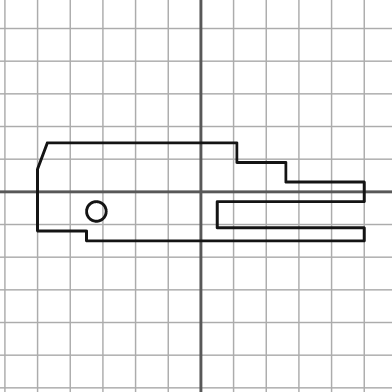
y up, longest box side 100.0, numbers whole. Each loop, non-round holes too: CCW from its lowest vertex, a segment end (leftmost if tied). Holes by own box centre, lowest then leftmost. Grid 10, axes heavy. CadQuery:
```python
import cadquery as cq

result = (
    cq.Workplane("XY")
    .moveTo(-35.0, -15.0)
    .lineTo(50.0, -15.0)
    .lineTo(50.0, -11.0)
    .lineTo(5.0, -11.0)
    .lineTo(5.0, -3.0)
    .lineTo(50.0, -3.0)
    .lineTo(50.0, 3.0)
    .lineTo(26.0, 3.0)
    .lineTo(26.0, 9.0)
    .lineTo(11.0, 9.0)
    .lineTo(11.0, 15.0)
    .lineTo(-47.0, 15.0)
    .lineTo(-50.0, 7.0)
    .lineTo(-50.0, -12.0)
    .lineTo(-35.0, -12.0)
    .close()
    .moveTo(-32.0, -6.0)
    .circle(3.0)
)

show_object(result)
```